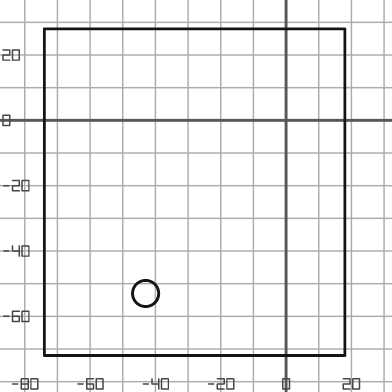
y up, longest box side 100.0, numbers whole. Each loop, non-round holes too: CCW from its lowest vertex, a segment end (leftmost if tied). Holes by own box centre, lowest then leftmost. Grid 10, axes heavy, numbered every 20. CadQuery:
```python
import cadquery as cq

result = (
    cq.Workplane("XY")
    .moveTo(-74.0, -72.0)
    .lineTo(18.0, -72.0)
    .lineTo(18.0, 28.0)
    .lineTo(-74.0, 28.0)
    .close()
    .moveTo(-43.0, -53.0)
    .circle(4.0)
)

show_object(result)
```